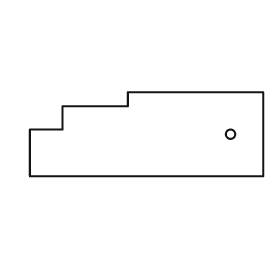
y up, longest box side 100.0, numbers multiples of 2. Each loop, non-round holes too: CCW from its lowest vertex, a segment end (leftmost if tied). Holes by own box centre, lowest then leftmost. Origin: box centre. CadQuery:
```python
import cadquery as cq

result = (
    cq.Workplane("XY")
    .moveTo(-50.0, -18.0)
    .lineTo(50.0, -18.0)
    .lineTo(50.0, 18.0)
    .lineTo(-8.0, 18.0)
    .lineTo(-8.0, 12.0)
    .lineTo(-36.0, 12.0)
    .lineTo(-36.0, 2.0)
    .lineTo(-50.0, 2.0)
    .close()
    .moveTo(36.0, 0.0)
    .circle(2.0)
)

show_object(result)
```